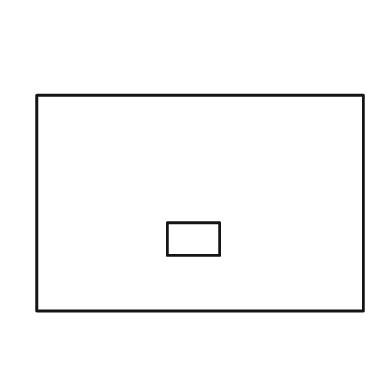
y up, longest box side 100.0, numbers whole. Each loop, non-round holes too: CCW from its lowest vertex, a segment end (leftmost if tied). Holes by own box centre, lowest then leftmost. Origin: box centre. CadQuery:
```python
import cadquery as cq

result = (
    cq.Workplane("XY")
    .moveTo(-50.0, -33.0)
    .lineTo(50.0, -33.0)
    .lineTo(50.0, 33.0)
    .lineTo(-50.0, 33.0)
    .close()
    .moveTo(-10.0, -16.0)
    .lineTo(6.0, -16.0)
    .lineTo(6.0, -6.0)
    .lineTo(-10.0, -6.0)
    .close()
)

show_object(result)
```